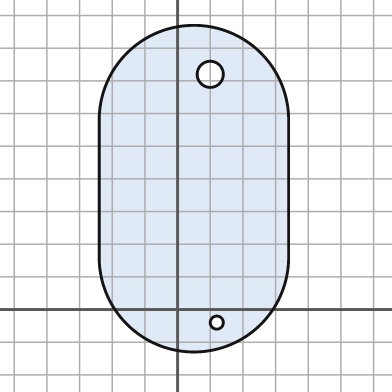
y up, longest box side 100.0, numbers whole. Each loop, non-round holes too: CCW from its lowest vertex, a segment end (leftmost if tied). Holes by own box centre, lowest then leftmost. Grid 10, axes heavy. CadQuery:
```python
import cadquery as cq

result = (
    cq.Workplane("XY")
    .moveTo(-24.0, 16.0)
    .threePointArc((5.0, -13.0), (34.0, 16.0))
    .lineTo(34.0, 58.0)
    .threePointArc((5.0, 87.0), (-24.0, 58.0))
    .close()
    .moveTo(12.0, -4.0)
    .circle(2.0)
    .moveTo(10.0, 72.0)
    .circle(4.0)
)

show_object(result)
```